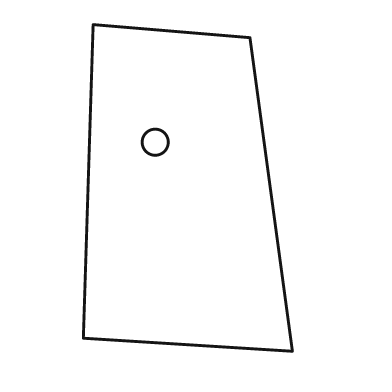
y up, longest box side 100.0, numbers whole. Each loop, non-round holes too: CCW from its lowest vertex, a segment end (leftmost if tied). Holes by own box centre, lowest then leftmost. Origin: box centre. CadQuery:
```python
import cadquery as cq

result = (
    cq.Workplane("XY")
    .moveTo(32.0, -50.0)
    .lineTo(19.0, 46.0)
    .lineTo(-29.0, 50.0)
    .lineTo(-32.0, -46.0)
    .close()
    .moveTo(-10.0, 14.0)
    .circle(4.0)
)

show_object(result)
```